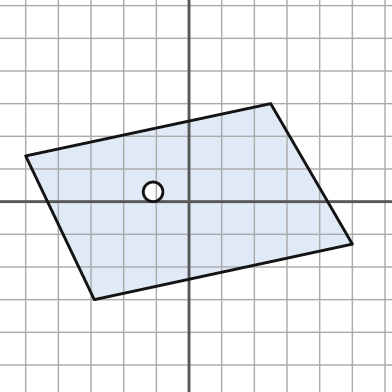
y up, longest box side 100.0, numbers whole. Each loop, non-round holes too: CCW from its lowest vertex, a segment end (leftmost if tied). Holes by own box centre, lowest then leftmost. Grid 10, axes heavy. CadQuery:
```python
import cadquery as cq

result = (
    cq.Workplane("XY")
    .moveTo(-29.0, -30.0)
    .lineTo(50.0, -13.0)
    .lineTo(25.0, 30.0)
    .lineTo(-50.0, 14.0)
    .close()
    .moveTo(-11.0, 3.0)
    .circle(3.0)
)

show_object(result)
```